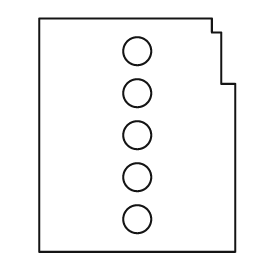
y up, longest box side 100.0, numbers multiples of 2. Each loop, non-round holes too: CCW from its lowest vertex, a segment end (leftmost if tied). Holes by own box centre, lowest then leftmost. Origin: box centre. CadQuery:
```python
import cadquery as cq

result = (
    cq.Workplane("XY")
    .moveTo(-42.0, -50.0)
    .lineTo(42.0, -50.0)
    .lineTo(42.0, 22.0)
    .lineTo(36.0, 22.0)
    .lineTo(36.0, 44.0)
    .lineTo(32.0, 44.0)
    .lineTo(32.0, 50.0)
    .lineTo(-42.0, 50.0)
    .close()
    .moveTo(0.0, -36.0)
    .circle(6.0)
    .moveTo(0.0, -18.0)
    .circle(6.0)
    .moveTo(0.0, 0.0)
    .circle(6.0)
    .moveTo(0.0, 18.0)
    .circle(6.0)
    .moveTo(0.0, 36.0)
    .circle(6.0)
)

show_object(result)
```